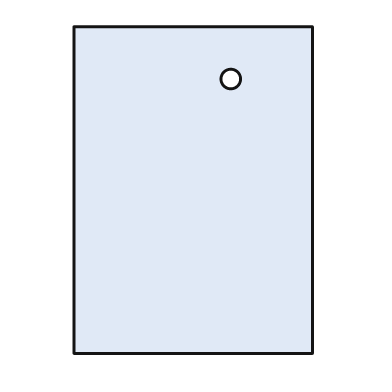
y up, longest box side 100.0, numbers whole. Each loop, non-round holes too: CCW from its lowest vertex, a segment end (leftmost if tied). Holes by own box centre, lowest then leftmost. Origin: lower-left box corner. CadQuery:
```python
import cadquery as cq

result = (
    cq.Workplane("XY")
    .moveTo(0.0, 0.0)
    .lineTo(73.0, 0.0)
    .lineTo(73.0, 100.0)
    .lineTo(0.0, 100.0)
    .close()
    .moveTo(48.0, 84.0)
    .circle(3.0)
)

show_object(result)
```